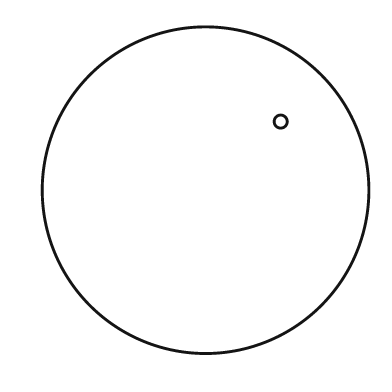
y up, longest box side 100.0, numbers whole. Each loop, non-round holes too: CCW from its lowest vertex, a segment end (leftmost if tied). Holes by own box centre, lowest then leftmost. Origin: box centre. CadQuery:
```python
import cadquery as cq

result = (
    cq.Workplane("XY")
    .moveTo(0.0, 0.0)
    .circle(50.0)
    .moveTo(23.0, 21.0)
    .circle(2.0)
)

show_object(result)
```